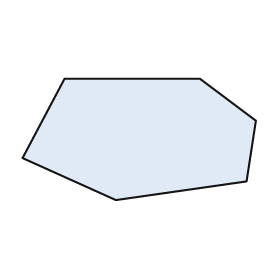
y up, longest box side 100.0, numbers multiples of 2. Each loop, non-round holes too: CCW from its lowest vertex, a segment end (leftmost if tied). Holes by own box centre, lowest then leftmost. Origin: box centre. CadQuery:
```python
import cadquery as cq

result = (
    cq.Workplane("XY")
    .moveTo(-10.0, -26.0)
    .lineTo(46.0, -18.0)
    .lineTo(50.0, 8.0)
    .lineTo(26.0, 26.0)
    .lineTo(-32.0, 26.0)
    .lineTo(-50.0, -8.0)
    .close()
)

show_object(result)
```